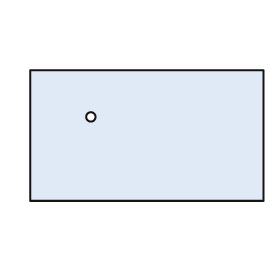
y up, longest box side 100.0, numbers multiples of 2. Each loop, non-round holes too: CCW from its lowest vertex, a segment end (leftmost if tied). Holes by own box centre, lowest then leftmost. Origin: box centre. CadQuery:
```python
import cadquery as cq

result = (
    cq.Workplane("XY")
    .moveTo(-50.0, -28.0)
    .lineTo(50.0, -28.0)
    .lineTo(50.0, 28.0)
    .lineTo(-50.0, 28.0)
    .close()
    .moveTo(-24.0, 8.0)
    .circle(2.0)
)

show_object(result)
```